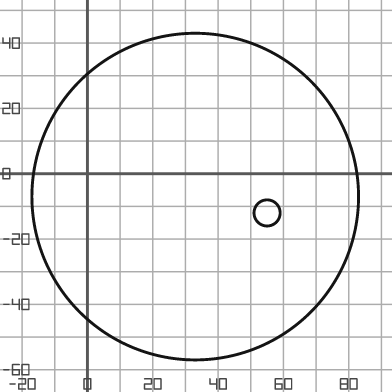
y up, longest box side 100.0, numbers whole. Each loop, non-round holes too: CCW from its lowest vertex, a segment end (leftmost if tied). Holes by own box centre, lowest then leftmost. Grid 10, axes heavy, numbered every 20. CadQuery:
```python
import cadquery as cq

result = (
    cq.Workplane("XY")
    .moveTo(33.0, -7.0)
    .circle(50.0)
    .moveTo(55.0, -12.0)
    .circle(4.0)
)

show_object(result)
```